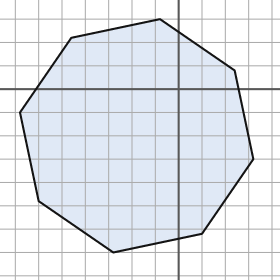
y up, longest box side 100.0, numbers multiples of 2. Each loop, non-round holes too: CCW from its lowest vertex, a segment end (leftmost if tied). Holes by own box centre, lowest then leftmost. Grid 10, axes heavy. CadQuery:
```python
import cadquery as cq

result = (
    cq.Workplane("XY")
    .moveTo(-28.0, -70.0)
    .lineTo(10.0, -62.0)
    .lineTo(32.0, -30.0)
    .lineTo(24.0, 8.0)
    .lineTo(-8.0, 30.0)
    .lineTo(-46.0, 22.0)
    .lineTo(-68.0, -10.0)
    .lineTo(-60.0, -48.0)
    .close()
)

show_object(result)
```